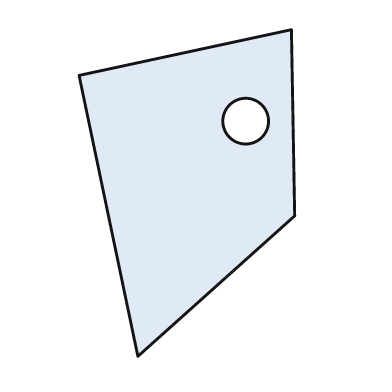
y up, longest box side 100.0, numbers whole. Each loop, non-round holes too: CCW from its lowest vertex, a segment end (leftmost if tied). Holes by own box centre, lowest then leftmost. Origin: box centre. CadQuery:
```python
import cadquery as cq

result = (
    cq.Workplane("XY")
    .moveTo(-15.0, -50.0)
    .lineTo(33.0, -7.0)
    .lineTo(32.0, 50.0)
    .lineTo(-33.0, 36.0)
    .close()
    .moveTo(18.0, 22.0)
    .circle(7.0)
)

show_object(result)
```